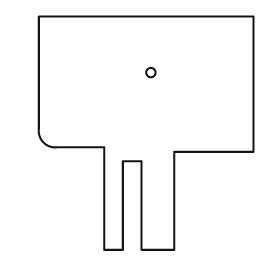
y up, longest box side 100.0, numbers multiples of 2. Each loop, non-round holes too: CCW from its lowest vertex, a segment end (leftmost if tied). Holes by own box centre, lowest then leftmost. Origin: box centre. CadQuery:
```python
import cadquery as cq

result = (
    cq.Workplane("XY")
    .moveTo(-18.0, -50.0)
    .lineTo(-10.0, -50.0)
    .lineTo(-10.0, -12.0)
    .lineTo(-2.0, -12.0)
    .lineTo(-2.0, -50.0)
    .lineTo(12.0, -50.0)
    .lineTo(12.0, -8.0)
    .lineTo(46.0, -8.0)
    .lineTo(46.0, 50.0)
    .lineTo(-46.0, 50.0)
    .lineTo(-46.0, 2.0)
    .threePointArc((-44.0, -4.0), (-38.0, -6.0))
    .lineTo(-18.0, -6.0)
    .close()
    .moveTo(2.0, 26.0)
    .circle(2.0)
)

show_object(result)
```